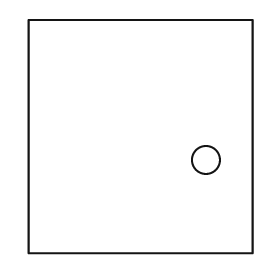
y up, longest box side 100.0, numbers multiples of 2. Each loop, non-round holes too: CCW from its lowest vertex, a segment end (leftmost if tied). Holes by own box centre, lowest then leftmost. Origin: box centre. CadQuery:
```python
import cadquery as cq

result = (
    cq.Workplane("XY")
    .moveTo(-48.0, -50.0)
    .lineTo(48.0, -50.0)
    .lineTo(48.0, 50.0)
    .lineTo(-48.0, 50.0)
    .close()
    .moveTo(28.0, -10.0)
    .circle(6.0)
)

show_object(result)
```